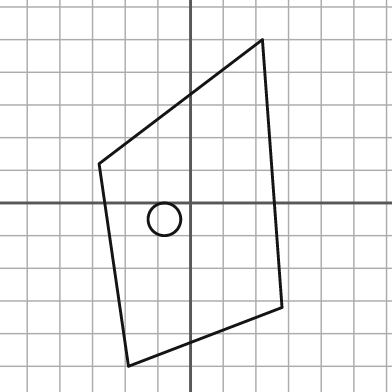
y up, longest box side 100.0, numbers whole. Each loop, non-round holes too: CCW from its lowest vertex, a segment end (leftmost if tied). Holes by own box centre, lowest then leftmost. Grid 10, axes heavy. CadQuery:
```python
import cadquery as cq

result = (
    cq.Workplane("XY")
    .moveTo(-19.0, -50.0)
    .lineTo(28.0, -32.0)
    .lineTo(22.0, 50.0)
    .lineTo(-28.0, 12.0)
    .close()
    .moveTo(-8.0, -5.0)
    .circle(5.0)
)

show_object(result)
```